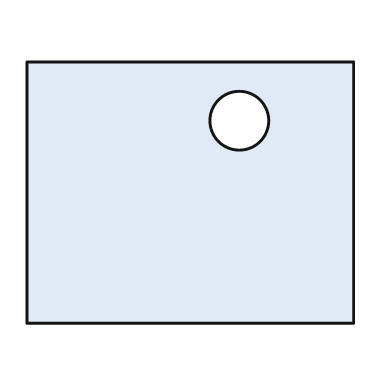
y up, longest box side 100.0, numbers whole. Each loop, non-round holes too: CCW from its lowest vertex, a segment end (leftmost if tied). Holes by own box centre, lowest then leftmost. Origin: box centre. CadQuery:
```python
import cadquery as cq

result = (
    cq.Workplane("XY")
    .moveTo(-50.0, -40.0)
    .lineTo(50.0, -40.0)
    .lineTo(50.0, 40.0)
    .lineTo(-50.0, 40.0)
    .close()
    .moveTo(15.0, 22.0)
    .circle(9.0)
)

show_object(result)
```